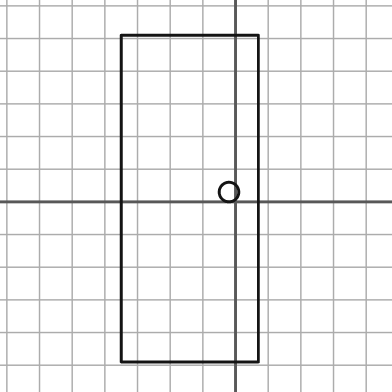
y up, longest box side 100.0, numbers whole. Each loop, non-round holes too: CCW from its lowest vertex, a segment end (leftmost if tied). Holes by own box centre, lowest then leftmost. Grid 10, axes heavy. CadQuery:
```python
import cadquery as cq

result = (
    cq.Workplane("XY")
    .moveTo(-35.0, -49.0)
    .lineTo(7.0, -49.0)
    .lineTo(7.0, 51.0)
    .lineTo(-35.0, 51.0)
    .close()
    .moveTo(-2.0, 3.0)
    .circle(3.0)
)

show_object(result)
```